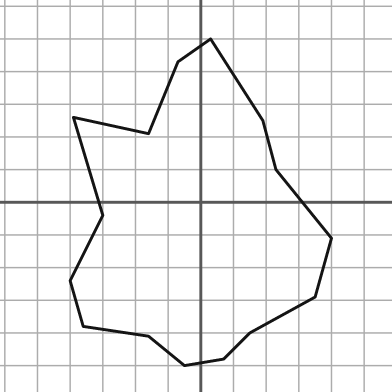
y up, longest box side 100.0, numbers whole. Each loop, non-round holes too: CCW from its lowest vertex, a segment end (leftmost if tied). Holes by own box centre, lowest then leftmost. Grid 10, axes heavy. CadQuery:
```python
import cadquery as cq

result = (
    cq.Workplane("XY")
    .moveTo(-5.0, -50.0)
    .lineTo(7.0, -48.0)
    .lineTo(15.0, -40.0)
    .lineTo(35.0, -29.0)
    .lineTo(40.0, -11.0)
    .lineTo(23.0, 10.0)
    .lineTo(19.0, 25.0)
    .lineTo(3.0, 50.0)
    .lineTo(-7.0, 43.0)
    .lineTo(-16.0, 21.0)
    .lineTo(-39.0, 26.0)
    .lineTo(-30.0, -4.0)
    .lineTo(-40.0, -24.0)
    .lineTo(-36.0, -38.0)
    .lineTo(-16.0, -41.0)
    .close()
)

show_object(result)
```